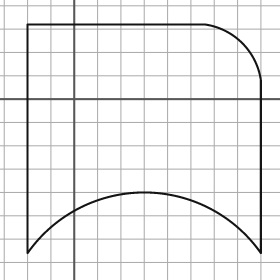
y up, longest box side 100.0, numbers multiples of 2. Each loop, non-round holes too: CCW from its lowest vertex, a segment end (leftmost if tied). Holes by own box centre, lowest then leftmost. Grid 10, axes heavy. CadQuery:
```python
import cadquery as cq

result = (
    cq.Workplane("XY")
    .moveTo(-20.0, -66.0)
    .threePointArc((30.0, -40.0), (80.0, -66.0))
    .lineTo(80.0, 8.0)
    .threePointArc((72.0, 24.0), (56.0, 32.0))
    .lineTo(-20.0, 32.0)
    .close()
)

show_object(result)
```